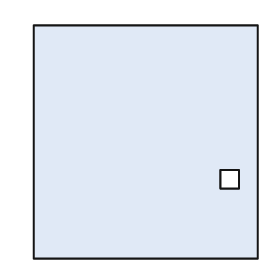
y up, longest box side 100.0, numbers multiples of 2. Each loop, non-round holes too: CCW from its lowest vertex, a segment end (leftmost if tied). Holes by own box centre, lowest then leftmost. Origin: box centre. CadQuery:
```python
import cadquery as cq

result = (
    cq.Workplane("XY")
    .moveTo(-48.0, -50.0)
    .lineTo(48.0, -50.0)
    .lineTo(48.0, 50.0)
    .lineTo(-48.0, 50.0)
    .close()
    .moveTo(32.0, -20.0)
    .lineTo(40.0, -20.0)
    .lineTo(40.0, -12.0)
    .lineTo(32.0, -12.0)
    .close()
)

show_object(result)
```